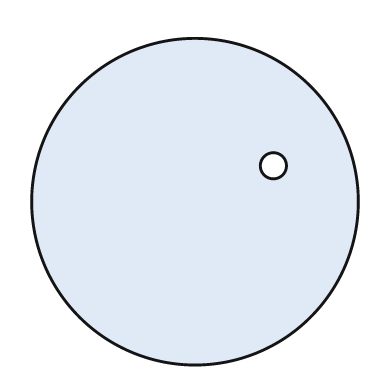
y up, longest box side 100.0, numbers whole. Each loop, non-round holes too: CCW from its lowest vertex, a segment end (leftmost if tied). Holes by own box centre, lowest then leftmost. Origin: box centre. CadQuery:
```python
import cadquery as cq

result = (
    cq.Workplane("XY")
    .moveTo(0.0, 0.0)
    .circle(50.0)
    .moveTo(24.0, 11.0)
    .circle(4.0)
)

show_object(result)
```